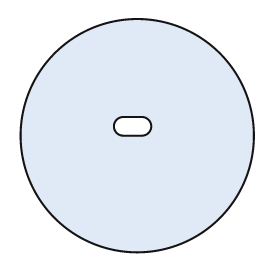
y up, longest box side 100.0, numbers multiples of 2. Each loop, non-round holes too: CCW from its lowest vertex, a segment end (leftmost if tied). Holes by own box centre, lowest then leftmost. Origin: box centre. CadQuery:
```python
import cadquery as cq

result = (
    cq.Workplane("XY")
    .moveTo(0.0, 0.0)
    .circle(50.0)
    .moveTo(-6.0, 0.0)
    .lineTo(2.0, 0.0)
    .threePointArc((6.0, 4.0), (2.0, 8.0))
    .lineTo(-6.0, 8.0)
    .threePointArc((-10.0, 4.0), (-6.0, 0.0))
    .close()
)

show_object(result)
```